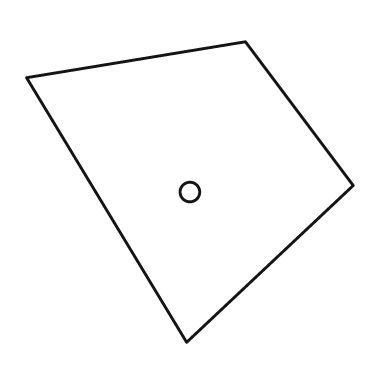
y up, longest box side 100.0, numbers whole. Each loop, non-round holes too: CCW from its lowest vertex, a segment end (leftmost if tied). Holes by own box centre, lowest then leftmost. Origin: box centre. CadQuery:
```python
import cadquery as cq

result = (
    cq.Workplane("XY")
    .moveTo(-1.0, -46.0)
    .lineTo(50.0, 2.0)
    .lineTo(17.0, 46.0)
    .lineTo(-50.0, 35.0)
    .close()
    .moveTo(0.0, 0.0)
    .circle(3.0)
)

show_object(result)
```